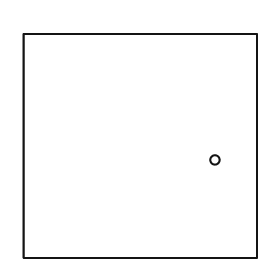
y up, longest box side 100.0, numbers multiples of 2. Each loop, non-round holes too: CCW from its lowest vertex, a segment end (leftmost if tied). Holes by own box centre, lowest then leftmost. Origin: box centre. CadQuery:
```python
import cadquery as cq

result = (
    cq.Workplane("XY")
    .moveTo(-50.0, -48.0)
    .lineTo(50.0, -48.0)
    .lineTo(50.0, 48.0)
    .lineTo(-50.0, 48.0)
    .close()
    .moveTo(32.0, -6.0)
    .circle(2.0)
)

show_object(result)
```